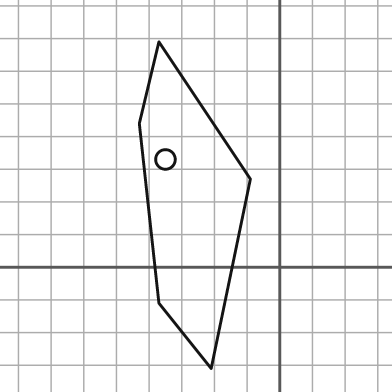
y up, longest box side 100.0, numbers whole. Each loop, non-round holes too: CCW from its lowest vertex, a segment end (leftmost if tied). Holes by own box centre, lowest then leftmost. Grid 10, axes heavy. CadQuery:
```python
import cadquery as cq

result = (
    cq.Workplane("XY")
    .moveTo(-21.0, -31.0)
    .lineTo(-9.0, 27.0)
    .lineTo(-37.0, 69.0)
    .lineTo(-43.0, 44.0)
    .lineTo(-37.0, -11.0)
    .close()
    .moveTo(-35.0, 33.0)
    .circle(3.0)
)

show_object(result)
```